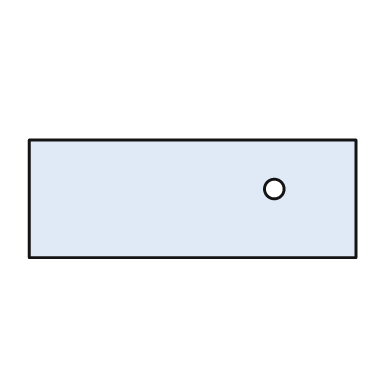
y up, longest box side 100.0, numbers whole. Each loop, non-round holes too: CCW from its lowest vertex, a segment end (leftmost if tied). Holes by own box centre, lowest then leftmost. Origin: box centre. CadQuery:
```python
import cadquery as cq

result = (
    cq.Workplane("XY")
    .moveTo(-50.0, -18.0)
    .lineTo(50.0, -18.0)
    .lineTo(50.0, 18.0)
    .lineTo(-50.0, 18.0)
    .close()
    .moveTo(25.0, 3.0)
    .circle(3.0)
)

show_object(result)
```